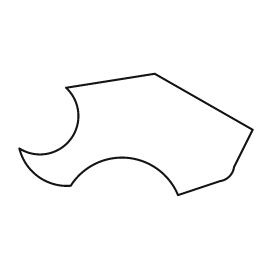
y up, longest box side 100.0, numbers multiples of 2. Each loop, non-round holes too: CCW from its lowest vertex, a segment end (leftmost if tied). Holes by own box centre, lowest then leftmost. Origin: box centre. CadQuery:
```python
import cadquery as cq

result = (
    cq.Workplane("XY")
    .moveTo(18.0, -26.0)
    .lineTo(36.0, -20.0)
    .threePointArc((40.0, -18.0), (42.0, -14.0))
    .lineTo(50.0, 2.0)
    .lineTo(8.0, 26.0)
    .lineTo(-30.0, 20.0)
    .threePointArc((-28.0, -2.0), (-50.0, -6.0))
    .threePointArc((-42.0, -18.0), (-28.0, -22.0))
    .threePointArc((-4.0, -10.0), (18.0, -26.0))
    .close()
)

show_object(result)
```